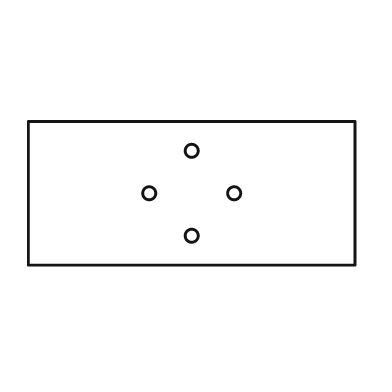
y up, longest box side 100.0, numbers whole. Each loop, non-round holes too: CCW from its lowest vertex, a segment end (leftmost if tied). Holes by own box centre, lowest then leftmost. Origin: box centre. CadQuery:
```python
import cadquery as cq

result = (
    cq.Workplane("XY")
    .moveTo(-50.0, -22.0)
    .lineTo(50.0, -22.0)
    .lineTo(50.0, 22.0)
    .lineTo(-50.0, 22.0)
    .close()
    .moveTo(0.0, -13.0)
    .circle(2.0)
    .moveTo(-13.0, 0.0)
    .circle(2.0)
    .moveTo(13.0, 0.0)
    .circle(2.0)
    .moveTo(0.0, 13.0)
    .circle(2.0)
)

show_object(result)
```